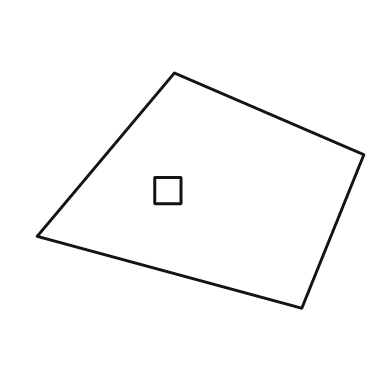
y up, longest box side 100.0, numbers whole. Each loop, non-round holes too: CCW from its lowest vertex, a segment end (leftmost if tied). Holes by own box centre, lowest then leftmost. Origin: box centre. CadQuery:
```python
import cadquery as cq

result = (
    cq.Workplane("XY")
    .moveTo(31.0, -36.0)
    .lineTo(50.0, 11.0)
    .lineTo(-8.0, 36.0)
    .lineTo(-50.0, -14.0)
    .close()
    .moveTo(-14.0, -4.0)
    .lineTo(-6.0, -4.0)
    .lineTo(-6.0, 4.0)
    .lineTo(-14.0, 4.0)
    .close()
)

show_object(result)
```